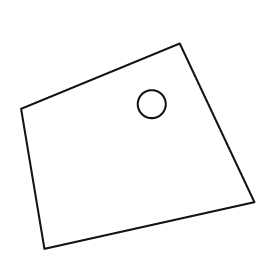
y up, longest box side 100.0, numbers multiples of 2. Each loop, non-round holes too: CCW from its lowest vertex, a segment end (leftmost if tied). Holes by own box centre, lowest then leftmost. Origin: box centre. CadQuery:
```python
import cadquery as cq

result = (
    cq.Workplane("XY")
    .moveTo(-40.0, -44.0)
    .lineTo(50.0, -24.0)
    .lineTo(18.0, 44.0)
    .lineTo(-50.0, 16.0)
    .close()
    .moveTo(6.0, 18.0)
    .circle(6.0)
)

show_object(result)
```